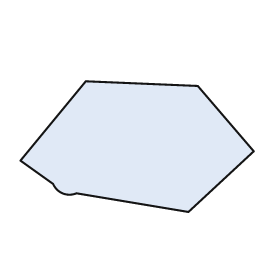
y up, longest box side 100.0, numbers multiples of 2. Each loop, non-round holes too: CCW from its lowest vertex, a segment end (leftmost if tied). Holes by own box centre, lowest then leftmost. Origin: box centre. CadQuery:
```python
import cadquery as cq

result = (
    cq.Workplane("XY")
    .moveTo(22.0, -28.0)
    .lineTo(50.0, -2.0)
    .lineTo(26.0, 26.0)
    .lineTo(-22.0, 28.0)
    .lineTo(-50.0, -6.0)
    .lineTo(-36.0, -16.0)
    .threePointArc((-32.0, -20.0), (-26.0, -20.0))
    .close()
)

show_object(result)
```